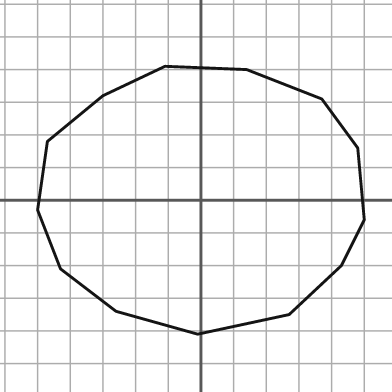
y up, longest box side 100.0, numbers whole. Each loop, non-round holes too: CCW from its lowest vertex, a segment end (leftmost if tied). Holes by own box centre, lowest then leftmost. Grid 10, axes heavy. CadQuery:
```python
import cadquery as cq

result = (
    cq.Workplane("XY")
    .moveTo(-1.0, -41.0)
    .lineTo(27.0, -35.0)
    .lineTo(43.0, -20.0)
    .lineTo(50.0, -6.0)
    .lineTo(48.0, 16.0)
    .lineTo(37.0, 31.0)
    .lineTo(14.0, 40.0)
    .lineTo(-11.0, 41.0)
    .lineTo(-30.0, 32.0)
    .lineTo(-47.0, 18.0)
    .lineTo(-50.0, -3.0)
    .lineTo(-43.0, -21.0)
    .lineTo(-26.0, -34.0)
    .close()
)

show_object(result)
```